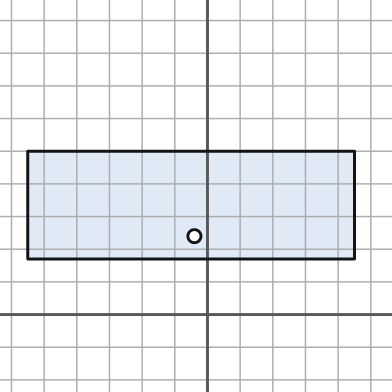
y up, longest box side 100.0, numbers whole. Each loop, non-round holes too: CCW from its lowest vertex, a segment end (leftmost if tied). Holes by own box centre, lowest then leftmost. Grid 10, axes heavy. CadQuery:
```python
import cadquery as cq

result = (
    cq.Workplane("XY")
    .moveTo(-55.0, 17.0)
    .lineTo(45.0, 17.0)
    .lineTo(45.0, 50.0)
    .lineTo(-55.0, 50.0)
    .close()
    .moveTo(-4.0, 24.0)
    .circle(2.0)
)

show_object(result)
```